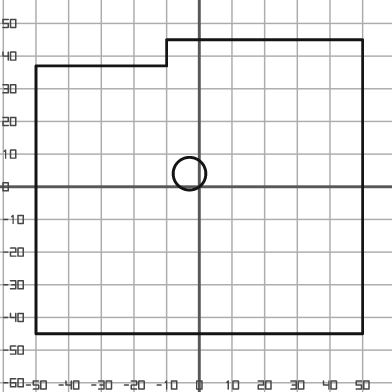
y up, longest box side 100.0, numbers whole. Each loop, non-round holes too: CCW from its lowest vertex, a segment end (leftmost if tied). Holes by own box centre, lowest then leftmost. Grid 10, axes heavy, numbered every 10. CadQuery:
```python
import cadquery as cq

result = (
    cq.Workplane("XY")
    .moveTo(-50.0, -45.0)
    .lineTo(50.0, -45.0)
    .lineTo(50.0, 45.0)
    .lineTo(-10.0, 45.0)
    .lineTo(-10.0, 37.0)
    .lineTo(-50.0, 37.0)
    .close()
    .moveTo(-3.0, 4.0)
    .circle(5.0)
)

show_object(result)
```